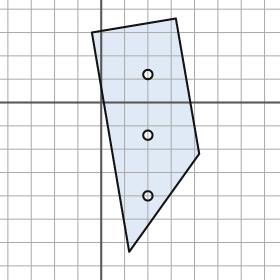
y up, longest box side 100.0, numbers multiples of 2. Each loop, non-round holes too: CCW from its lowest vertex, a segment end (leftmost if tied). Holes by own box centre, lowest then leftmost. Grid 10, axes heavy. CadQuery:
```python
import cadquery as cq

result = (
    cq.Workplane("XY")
    .moveTo(12.0, -64.0)
    .lineTo(42.0, -22.0)
    .lineTo(32.0, 36.0)
    .lineTo(-4.0, 30.0)
    .close()
    .moveTo(20.0, -40.0)
    .circle(2.0)
    .moveTo(20.0, -14.0)
    .circle(2.0)
    .moveTo(20.0, 12.0)
    .circle(2.0)
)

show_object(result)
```